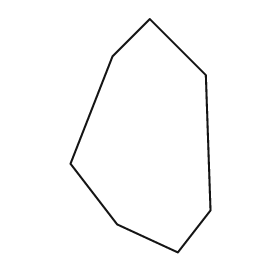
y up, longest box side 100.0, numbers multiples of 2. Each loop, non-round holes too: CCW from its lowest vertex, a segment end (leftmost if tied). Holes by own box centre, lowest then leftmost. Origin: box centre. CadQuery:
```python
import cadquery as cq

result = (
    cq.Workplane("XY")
    .moveTo(16.0, -50.0)
    .lineTo(30.0, -32.0)
    .lineTo(28.0, 26.0)
    .lineTo(4.0, 50.0)
    .lineTo(-12.0, 34.0)
    .lineTo(-30.0, -12.0)
    .lineTo(-10.0, -38.0)
    .close()
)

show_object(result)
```